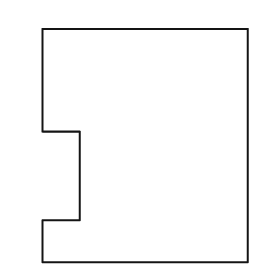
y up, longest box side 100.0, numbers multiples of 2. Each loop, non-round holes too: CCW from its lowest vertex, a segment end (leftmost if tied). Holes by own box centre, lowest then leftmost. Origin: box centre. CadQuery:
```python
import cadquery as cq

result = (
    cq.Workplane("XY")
    .moveTo(-44.0, -50.0)
    .lineTo(44.0, -50.0)
    .lineTo(44.0, 50.0)
    .lineTo(-44.0, 50.0)
    .lineTo(-44.0, 6.0)
    .lineTo(-28.0, 6.0)
    .lineTo(-28.0, -32.0)
    .lineTo(-44.0, -32.0)
    .close()
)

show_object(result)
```